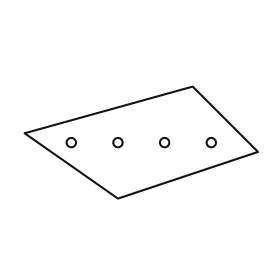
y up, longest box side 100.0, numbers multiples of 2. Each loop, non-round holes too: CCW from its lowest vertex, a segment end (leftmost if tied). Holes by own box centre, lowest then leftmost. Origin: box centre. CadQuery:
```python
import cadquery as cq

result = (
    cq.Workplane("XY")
    .moveTo(-10.0, -24.0)
    .lineTo(50.0, -4.0)
    .lineTo(22.0, 24.0)
    .lineTo(-50.0, 4.0)
    .close()
    .moveTo(-30.0, 0.0)
    .circle(2.0)
    .moveTo(-10.0, 0.0)
    .circle(2.0)
    .moveTo(10.0, 0.0)
    .circle(2.0)
    .moveTo(30.0, 0.0)
    .circle(2.0)
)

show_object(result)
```